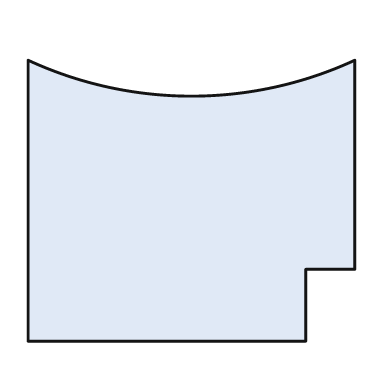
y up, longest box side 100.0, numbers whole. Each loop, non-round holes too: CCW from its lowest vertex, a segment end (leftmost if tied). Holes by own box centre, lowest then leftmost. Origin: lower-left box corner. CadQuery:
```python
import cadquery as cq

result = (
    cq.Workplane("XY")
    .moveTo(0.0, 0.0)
    .lineTo(85.0, 0.0)
    .lineTo(85.0, 22.0)
    .lineTo(100.0, 22.0)
    .lineTo(100.0, 86.0)
    .threePointArc((50.0, 75.0), (0.0, 86.0))
    .close()
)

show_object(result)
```